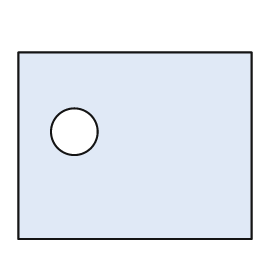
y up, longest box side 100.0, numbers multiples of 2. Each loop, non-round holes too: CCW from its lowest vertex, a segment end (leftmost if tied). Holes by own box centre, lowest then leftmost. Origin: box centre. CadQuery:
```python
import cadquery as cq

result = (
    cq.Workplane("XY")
    .moveTo(-50.0, -40.0)
    .lineTo(50.0, -40.0)
    .lineTo(50.0, 40.0)
    .lineTo(-50.0, 40.0)
    .close()
    .moveTo(-26.0, 6.0)
    .circle(10.0)
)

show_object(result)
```